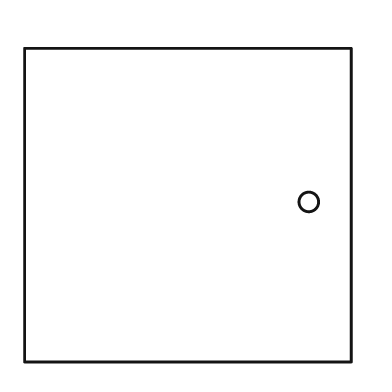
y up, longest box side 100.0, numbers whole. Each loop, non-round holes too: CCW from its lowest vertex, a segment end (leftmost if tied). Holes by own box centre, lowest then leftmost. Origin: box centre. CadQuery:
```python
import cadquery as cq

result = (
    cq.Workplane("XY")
    .moveTo(-50.0, -48.0)
    .lineTo(50.0, -48.0)
    .lineTo(50.0, 48.0)
    .lineTo(-50.0, 48.0)
    .close()
    .moveTo(37.0, 1.0)
    .circle(3.0)
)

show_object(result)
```